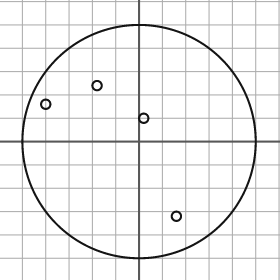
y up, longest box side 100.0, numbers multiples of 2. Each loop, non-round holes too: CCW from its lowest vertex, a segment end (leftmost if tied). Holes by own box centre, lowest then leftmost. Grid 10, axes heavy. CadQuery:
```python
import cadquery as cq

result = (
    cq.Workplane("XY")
    .moveTo(0.0, 0.0)
    .circle(50.0)
    .moveTo(16.0, -32.0)
    .circle(2.0)
    .moveTo(2.0, 10.0)
    .circle(2.0)
    .moveTo(-40.0, 16.0)
    .circle(2.0)
    .moveTo(-18.0, 24.0)
    .circle(2.0)
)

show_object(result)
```